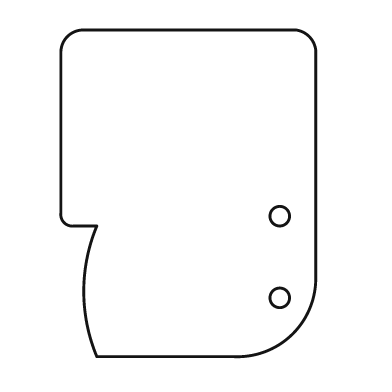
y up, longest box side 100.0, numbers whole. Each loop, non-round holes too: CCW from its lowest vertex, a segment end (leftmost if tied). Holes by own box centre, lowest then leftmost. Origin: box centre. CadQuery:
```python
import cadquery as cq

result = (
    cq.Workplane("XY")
    .moveTo(-28.0, -50.0)
    .lineTo(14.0, -50.0)
    .threePointArc((32.0, -43.0), (39.0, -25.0))
    .lineTo(39.0, 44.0)
    .threePointArc((37.0, 48.0), (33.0, 50.0))
    .lineTo(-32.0, 50.0)
    .threePointArc((-37.0, 48.0), (-39.0, 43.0))
    .lineTo(-39.0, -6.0)
    .threePointArc((-38.0, -9.0), (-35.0, -10.0))
    .lineTo(-28.0, -10.0)
    .threePointArc((-32.0, -30.0), (-28.0, -50.0))
    .close()
    .moveTo(28.0, -32.0)
    .circle(3.0)
    .moveTo(28.0, -7.0)
    .circle(3.0)
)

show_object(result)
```